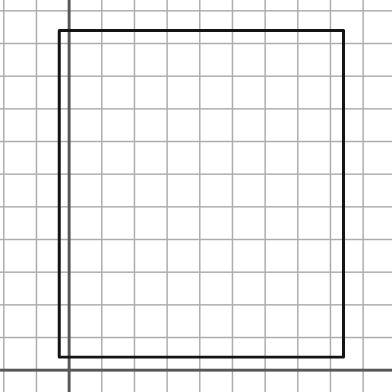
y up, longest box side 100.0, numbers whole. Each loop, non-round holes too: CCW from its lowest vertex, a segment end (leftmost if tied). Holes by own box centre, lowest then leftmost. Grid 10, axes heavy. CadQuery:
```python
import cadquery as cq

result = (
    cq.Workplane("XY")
    .moveTo(-3.0, 4.0)
    .lineTo(84.0, 4.0)
    .lineTo(84.0, 104.0)
    .lineTo(-3.0, 104.0)
    .close()
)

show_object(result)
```